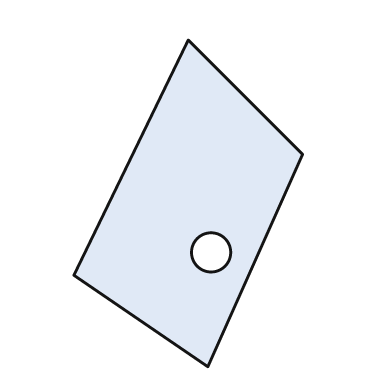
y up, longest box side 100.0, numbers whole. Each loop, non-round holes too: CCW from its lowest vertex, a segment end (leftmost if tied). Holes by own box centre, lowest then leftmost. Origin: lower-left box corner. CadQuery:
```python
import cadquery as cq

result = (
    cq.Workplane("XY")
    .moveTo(41.0, 0.0)
    .lineTo(70.0, 65.0)
    .lineTo(35.0, 100.0)
    .lineTo(0.0, 28.0)
    .close()
    .moveTo(42.0, 35.0)
    .circle(6.0)
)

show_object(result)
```